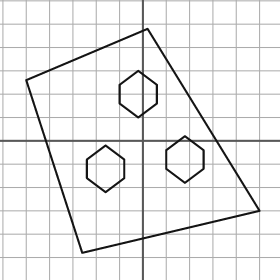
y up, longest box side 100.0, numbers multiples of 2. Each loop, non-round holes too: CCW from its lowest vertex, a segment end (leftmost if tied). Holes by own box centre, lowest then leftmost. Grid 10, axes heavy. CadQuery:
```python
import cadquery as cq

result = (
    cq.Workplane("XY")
    .moveTo(-26.0, -48.0)
    .lineTo(50.0, -30.0)
    .lineTo(2.0, 48.0)
    .lineTo(-50.0, 26.0)
    .close()
    .moveTo(-16.0, -22.0)
    .lineTo(-8.0, -16.0)
    .lineTo(-8.0, -8.0)
    .lineTo(-16.0, -2.0)
    .lineTo(-24.0, -8.0)
    .lineTo(-24.0, -16.0)
    .close()
    .moveTo(18.0, -18.0)
    .lineTo(26.0, -12.0)
    .lineTo(26.0, -4.0)
    .lineTo(18.0, 2.0)
    .lineTo(10.0, -4.0)
    .lineTo(10.0, -12.0)
    .close()
    .moveTo(-2.0, 10.0)
    .lineTo(6.0, 16.0)
    .lineTo(6.0, 24.0)
    .lineTo(-2.0, 30.0)
    .lineTo(-10.0, 24.0)
    .lineTo(-10.0, 16.0)
    .close()
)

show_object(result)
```